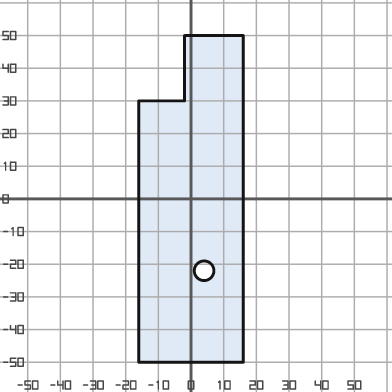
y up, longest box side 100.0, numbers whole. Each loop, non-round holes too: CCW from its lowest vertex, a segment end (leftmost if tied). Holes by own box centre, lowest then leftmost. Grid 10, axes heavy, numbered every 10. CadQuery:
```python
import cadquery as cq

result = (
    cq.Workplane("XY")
    .moveTo(-16.0, -50.0)
    .lineTo(16.0, -50.0)
    .lineTo(16.0, 50.0)
    .lineTo(-2.0, 50.0)
    .lineTo(-2.0, 30.0)
    .lineTo(-16.0, 30.0)
    .close()
    .moveTo(4.0, -22.0)
    .circle(3.0)
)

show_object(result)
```